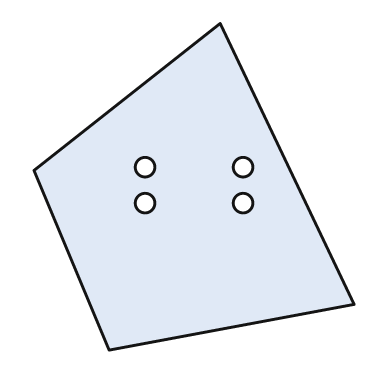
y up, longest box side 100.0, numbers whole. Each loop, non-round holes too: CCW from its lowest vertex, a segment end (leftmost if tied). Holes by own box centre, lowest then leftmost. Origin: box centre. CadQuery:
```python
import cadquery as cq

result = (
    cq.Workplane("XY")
    .moveTo(-26.0, -50.0)
    .lineTo(49.0, -36.0)
    .lineTo(8.0, 50.0)
    .lineTo(-49.0, 5.0)
    .close()
    .moveTo(-15.0, -5.0)
    .circle(3.0)
    .moveTo(15.0, -5.0)
    .circle(3.0)
    .moveTo(-15.0, 6.0)
    .circle(3.0)
    .moveTo(15.0, 6.0)
    .circle(3.0)
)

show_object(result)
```